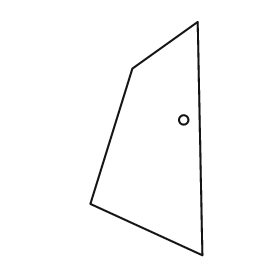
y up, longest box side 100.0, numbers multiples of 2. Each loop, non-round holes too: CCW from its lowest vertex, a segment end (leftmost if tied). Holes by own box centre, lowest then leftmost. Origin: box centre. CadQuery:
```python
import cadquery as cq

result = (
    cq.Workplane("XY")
    .moveTo(24.0, -50.0)
    .lineTo(22.0, 50.0)
    .lineTo(-6.0, 30.0)
    .lineTo(-24.0, -28.0)
    .close()
    .moveTo(16.0, 8.0)
    .circle(2.0)
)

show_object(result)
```